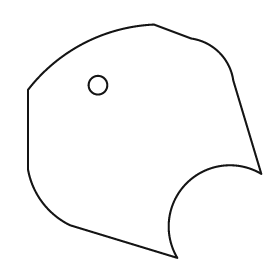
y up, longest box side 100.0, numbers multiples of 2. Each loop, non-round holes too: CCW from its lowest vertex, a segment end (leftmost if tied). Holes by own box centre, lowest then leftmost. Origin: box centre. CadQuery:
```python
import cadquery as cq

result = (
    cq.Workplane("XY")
    .moveTo(14.0, -50.0)
    .threePointArc((18.0, -18.0), (50.0, -14.0))
    .lineTo(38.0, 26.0)
    .threePointArc((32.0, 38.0), (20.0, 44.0))
    .lineTo(4.0, 50.0)
    .threePointArc((-26.0, 42.0), (-50.0, 22.0))
    .lineTo(-50.0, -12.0)
    .threePointArc((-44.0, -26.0), (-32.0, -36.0))
    .close()
    .moveTo(-20.0, 24.0)
    .circle(4.0)
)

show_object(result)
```